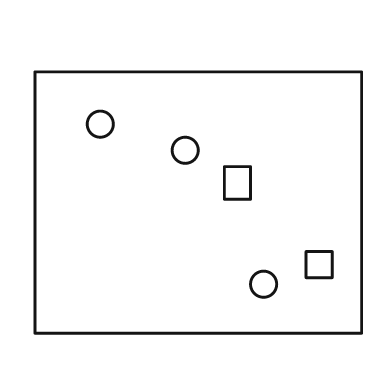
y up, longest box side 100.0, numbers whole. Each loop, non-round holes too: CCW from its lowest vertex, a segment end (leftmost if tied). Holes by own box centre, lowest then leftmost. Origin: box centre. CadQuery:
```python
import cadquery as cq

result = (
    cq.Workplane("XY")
    .moveTo(-50.0, -40.0)
    .lineTo(50.0, -40.0)
    .lineTo(50.0, 40.0)
    .lineTo(-50.0, 40.0)
    .close()
    .moveTo(20.0, -25.0)
    .circle(4.0)
    .moveTo(33.0, -23.0)
    .lineTo(41.0, -23.0)
    .lineTo(41.0, -15.0)
    .lineTo(33.0, -15.0)
    .close()
    .moveTo(8.0, 1.0)
    .lineTo(16.0, 1.0)
    .lineTo(16.0, 11.0)
    .lineTo(8.0, 11.0)
    .close()
    .moveTo(-4.0, 16.0)
    .circle(4.0)
    .moveTo(-30.0, 24.0)
    .circle(4.0)
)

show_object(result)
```